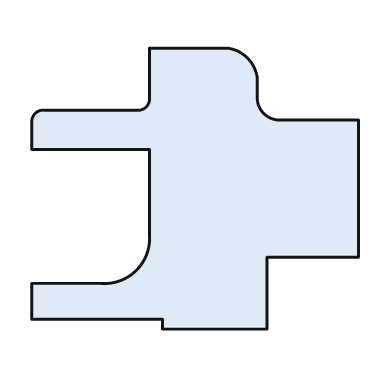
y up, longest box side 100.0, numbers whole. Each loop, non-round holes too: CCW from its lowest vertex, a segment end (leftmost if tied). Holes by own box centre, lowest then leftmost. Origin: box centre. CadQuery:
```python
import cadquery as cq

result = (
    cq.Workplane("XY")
    .moveTo(-10.0, -43.0)
    .lineTo(22.0, -43.0)
    .lineTo(22.0, -21.0)
    .lineTo(50.0, -21.0)
    .lineTo(50.0, 21.0)
    .lineTo(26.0, 21.0)
    .threePointArc((21.0, 23.0), (19.0, 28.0))
    .lineTo(19.0, 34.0)
    .threePointArc((16.0, 40.0), (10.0, 43.0))
    .lineTo(-14.0, 43.0)
    .lineTo(-14.0, 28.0)
    .threePointArc((-15.0, 25.0), (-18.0, 24.0))
    .lineTo(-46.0, 24.0)
    .threePointArc((-49.0, 23.0), (-50.0, 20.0))
    .lineTo(-50.0, 12.0)
    .lineTo(-14.0, 12.0)
    .lineTo(-14.0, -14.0)
    .threePointArc((-18.0, -25.0), (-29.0, -29.0))
    .lineTo(-50.0, -29.0)
    .lineTo(-50.0, -40.0)
    .lineTo(-10.0, -40.0)
    .close()
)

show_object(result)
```